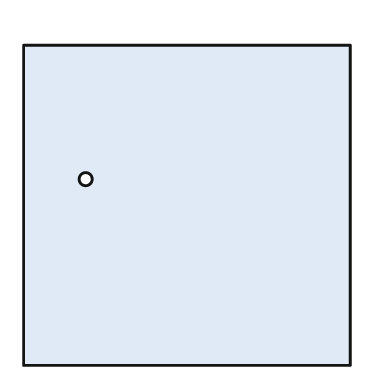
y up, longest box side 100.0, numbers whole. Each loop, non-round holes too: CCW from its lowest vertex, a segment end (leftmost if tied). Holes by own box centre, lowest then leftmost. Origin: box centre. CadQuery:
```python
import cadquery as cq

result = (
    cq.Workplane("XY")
    .moveTo(-50.0, -49.0)
    .lineTo(50.0, -49.0)
    .lineTo(50.0, 49.0)
    .lineTo(-50.0, 49.0)
    .close()
    .moveTo(-31.0, 8.0)
    .circle(2.0)
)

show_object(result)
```